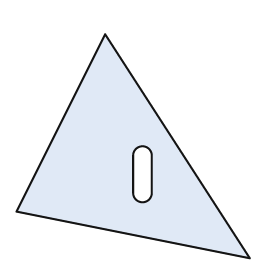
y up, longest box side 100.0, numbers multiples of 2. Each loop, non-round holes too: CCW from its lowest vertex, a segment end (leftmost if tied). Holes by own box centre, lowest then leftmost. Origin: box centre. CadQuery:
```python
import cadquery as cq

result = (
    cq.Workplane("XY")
    .moveTo(50.0, -48.0)
    .lineTo(-12.0, 48.0)
    .lineTo(-50.0, -28.0)
    .close()
    .moveTo(0.0, -20.0)
    .threePointArc((4.0, -24.0), (8.0, -20.0))
    .lineTo(8.0, -4.0)
    .threePointArc((4.0, 0.0), (0.0, -4.0))
    .close()
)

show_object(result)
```